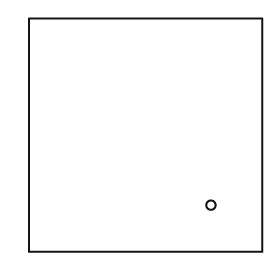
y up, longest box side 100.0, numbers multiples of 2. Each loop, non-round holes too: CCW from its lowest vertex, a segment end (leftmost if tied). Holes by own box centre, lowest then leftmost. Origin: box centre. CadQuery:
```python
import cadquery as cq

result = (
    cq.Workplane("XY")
    .moveTo(-50.0, -50.0)
    .lineTo(50.0, -50.0)
    .lineTo(50.0, 50.0)
    .lineTo(-50.0, 50.0)
    .close()
    .moveTo(28.0, -30.0)
    .circle(2.0)
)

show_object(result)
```